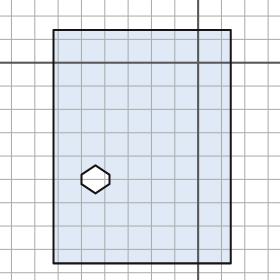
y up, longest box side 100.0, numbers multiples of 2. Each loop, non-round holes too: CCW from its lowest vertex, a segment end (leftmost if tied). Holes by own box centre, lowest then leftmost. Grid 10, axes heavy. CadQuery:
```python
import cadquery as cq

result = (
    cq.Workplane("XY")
    .moveTo(-62.0, -86.0)
    .lineTo(14.0, -86.0)
    .lineTo(14.0, 14.0)
    .lineTo(-62.0, 14.0)
    .close()
    .moveTo(-44.0, -56.0)
    .lineTo(-38.0, -52.0)
    .lineTo(-38.0, -48.0)
    .lineTo(-44.0, -44.0)
    .lineTo(-50.0, -48.0)
    .lineTo(-50.0, -52.0)
    .close()
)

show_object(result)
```